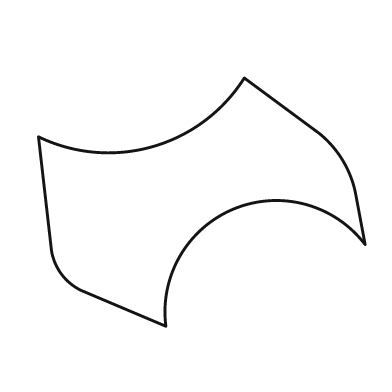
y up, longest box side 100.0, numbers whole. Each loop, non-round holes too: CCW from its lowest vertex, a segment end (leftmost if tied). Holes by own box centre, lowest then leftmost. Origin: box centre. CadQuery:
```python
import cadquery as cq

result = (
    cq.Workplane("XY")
    .moveTo(-11.0, -38.0)
    .threePointArc((10.0, -2.0), (50.0, -13.0))
    .lineTo(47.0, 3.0)
    .threePointArc((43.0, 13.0), (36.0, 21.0))
    .lineTo(13.0, 38.0)
    .threePointArc((-15.0, 17.0), (-50.0, 20.0))
    .lineTo(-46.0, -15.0)
    .threePointArc((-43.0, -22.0), (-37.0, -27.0))
    .close()
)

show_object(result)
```